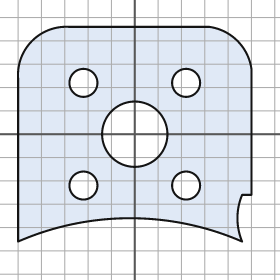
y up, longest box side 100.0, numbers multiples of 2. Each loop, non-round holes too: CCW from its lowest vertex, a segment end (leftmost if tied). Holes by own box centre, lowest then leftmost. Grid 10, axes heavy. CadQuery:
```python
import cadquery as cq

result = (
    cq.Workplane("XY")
    .moveTo(-50.0, -46.0)
    .threePointArc((-2.0, -36.0), (46.0, -46.0))
    .threePointArc((44.0, -36.0), (46.0, -26.0))
    .lineTo(50.0, -26.0)
    .lineTo(50.0, 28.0)
    .threePointArc((44.0, 40.0), (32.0, 46.0))
    .lineTo(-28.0, 46.0)
    .threePointArc((-44.0, 40.0), (-50.0, 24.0))
    .close()
    .moveTo(-22.0, -22.0)
    .circle(6.0)
    .moveTo(22.0, -22.0)
    .circle(6.0)
    .moveTo(0.0, 0.0)
    .circle(14.0)
    .moveTo(-22.0, 22.0)
    .circle(6.0)
    .moveTo(22.0, 22.0)
    .circle(6.0)
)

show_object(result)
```